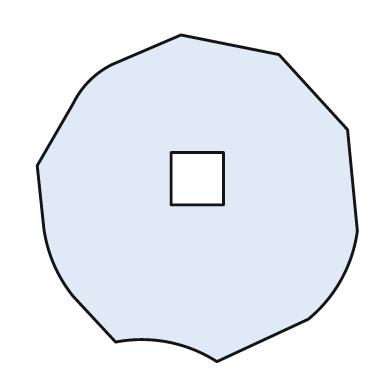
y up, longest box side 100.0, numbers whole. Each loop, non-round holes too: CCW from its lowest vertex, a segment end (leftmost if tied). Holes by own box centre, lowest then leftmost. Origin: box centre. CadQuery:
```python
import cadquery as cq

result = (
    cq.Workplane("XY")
    .moveTo(6.0, -50.0)
    .lineTo(34.0, -37.0)
    .threePointArc((44.0, -25.0), (49.0, -10.0))
    .lineTo(46.0, 21.0)
    .lineTo(25.0, 44.0)
    .lineTo(-5.0, 50.0)
    .lineTo(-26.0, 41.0)
    .threePointArc((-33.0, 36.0), (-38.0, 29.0))
    .lineTo(-49.0, 10.0)
    .lineTo(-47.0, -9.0)
    .threePointArc((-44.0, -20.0), (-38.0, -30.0))
    .lineTo(-25.0, -44.0)
    .threePointArc((-9.0, -44.0), (6.0, -50.0))
    .close()
    .moveTo(-8.0, -2.0)
    .lineTo(8.0, -2.0)
    .lineTo(8.0, 14.0)
    .lineTo(-8.0, 14.0)
    .close()
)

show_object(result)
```